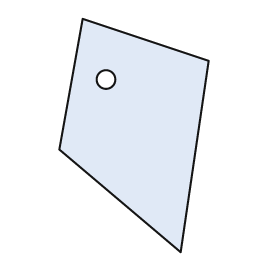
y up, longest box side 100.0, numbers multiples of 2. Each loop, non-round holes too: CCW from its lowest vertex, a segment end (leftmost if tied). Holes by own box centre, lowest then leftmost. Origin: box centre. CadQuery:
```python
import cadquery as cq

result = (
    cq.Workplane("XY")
    .moveTo(20.0, -50.0)
    .lineTo(32.0, 32.0)
    .lineTo(-22.0, 50.0)
    .lineTo(-32.0, -6.0)
    .close()
    .moveTo(-12.0, 24.0)
    .circle(4.0)
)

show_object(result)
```